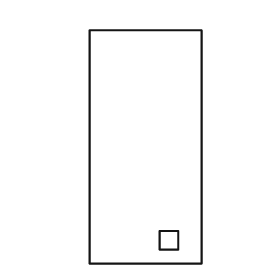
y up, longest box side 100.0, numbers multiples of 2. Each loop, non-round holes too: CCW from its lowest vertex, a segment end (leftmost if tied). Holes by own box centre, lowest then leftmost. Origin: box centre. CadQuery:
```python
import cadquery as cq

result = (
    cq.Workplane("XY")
    .moveTo(-24.0, -50.0)
    .lineTo(24.0, -50.0)
    .lineTo(24.0, 50.0)
    .lineTo(-24.0, 50.0)
    .close()
    .moveTo(6.0, -44.0)
    .lineTo(14.0, -44.0)
    .lineTo(14.0, -36.0)
    .lineTo(6.0, -36.0)
    .close()
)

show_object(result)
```